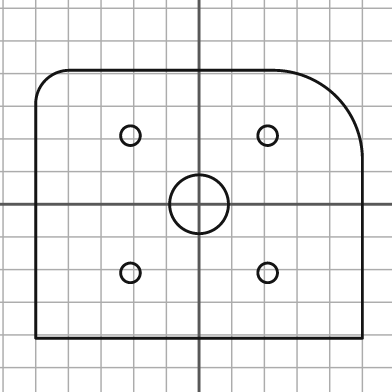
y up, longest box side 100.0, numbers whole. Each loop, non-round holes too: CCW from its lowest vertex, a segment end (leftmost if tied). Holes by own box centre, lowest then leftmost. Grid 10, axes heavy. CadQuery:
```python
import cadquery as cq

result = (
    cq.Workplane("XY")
    .moveTo(-50.0, -41.0)
    .lineTo(50.0, -41.0)
    .lineTo(50.0, 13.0)
    .threePointArc((42.0, 33.0), (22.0, 41.0))
    .lineTo(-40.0, 41.0)
    .threePointArc((-47.0, 38.0), (-50.0, 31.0))
    .close()
    .moveTo(-21.0, -21.0)
    .circle(3.0)
    .moveTo(21.0, -21.0)
    .circle(3.0)
    .moveTo(0.0, 0.0)
    .circle(9.0)
    .moveTo(-21.0, 21.0)
    .circle(3.0)
    .moveTo(21.0, 21.0)
    .circle(3.0)
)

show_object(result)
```